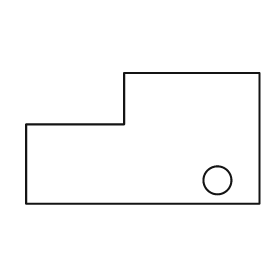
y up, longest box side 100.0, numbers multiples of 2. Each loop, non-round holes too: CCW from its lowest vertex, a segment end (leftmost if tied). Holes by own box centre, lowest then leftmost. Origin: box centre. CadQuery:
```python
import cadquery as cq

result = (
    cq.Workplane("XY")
    .moveTo(-50.0, -28.0)
    .lineTo(50.0, -28.0)
    .lineTo(50.0, 28.0)
    .lineTo(-8.0, 28.0)
    .lineTo(-8.0, 6.0)
    .lineTo(-50.0, 6.0)
    .close()
    .moveTo(32.0, -18.0)
    .circle(6.0)
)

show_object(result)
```